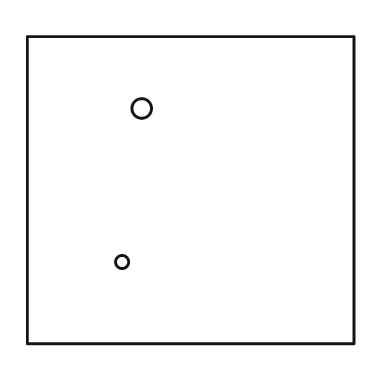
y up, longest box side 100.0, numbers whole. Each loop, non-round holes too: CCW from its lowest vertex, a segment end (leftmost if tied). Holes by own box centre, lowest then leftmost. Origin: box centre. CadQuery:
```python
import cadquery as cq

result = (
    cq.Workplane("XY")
    .moveTo(-50.0, -47.0)
    .lineTo(50.0, -47.0)
    .lineTo(50.0, 47.0)
    .lineTo(-50.0, 47.0)
    .close()
    .moveTo(-21.0, -22.0)
    .circle(2.0)
    .moveTo(-15.0, 25.0)
    .circle(3.0)
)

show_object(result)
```